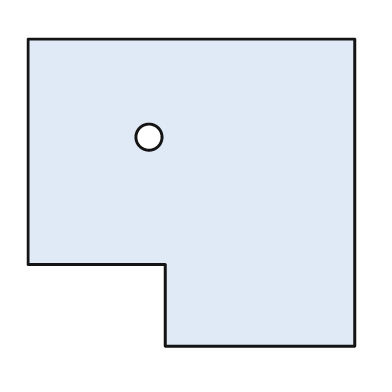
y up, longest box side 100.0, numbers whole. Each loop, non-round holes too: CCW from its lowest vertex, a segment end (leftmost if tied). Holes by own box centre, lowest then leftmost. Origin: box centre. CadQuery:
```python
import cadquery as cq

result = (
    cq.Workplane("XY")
    .moveTo(-8.0, -47.0)
    .lineTo(50.0, -47.0)
    .lineTo(50.0, 47.0)
    .lineTo(-50.0, 47.0)
    .lineTo(-50.0, -22.0)
    .lineTo(-8.0, -22.0)
    .close()
    .moveTo(-13.0, 17.0)
    .circle(4.0)
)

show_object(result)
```